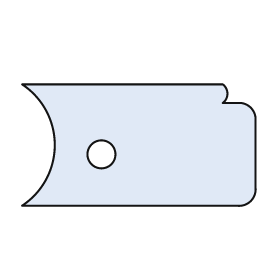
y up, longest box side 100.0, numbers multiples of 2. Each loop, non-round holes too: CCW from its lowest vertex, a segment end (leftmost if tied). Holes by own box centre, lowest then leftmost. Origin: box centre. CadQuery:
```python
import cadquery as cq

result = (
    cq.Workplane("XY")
    .moveTo(-50.0, -26.0)
    .lineTo(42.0, -26.0)
    .threePointArc((48.0, -24.0), (50.0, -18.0))
    .lineTo(50.0, 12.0)
    .threePointArc((48.0, 16.0), (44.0, 18.0))
    .lineTo(36.0, 18.0)
    .threePointArc((38.0, 22.0), (36.0, 26.0))
    .lineTo(-50.0, 26.0)
    .threePointArc((-36.0, 0.0), (-50.0, -26.0))
    .close()
    .moveTo(-16.0, -4.0)
    .circle(6.0)
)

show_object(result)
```